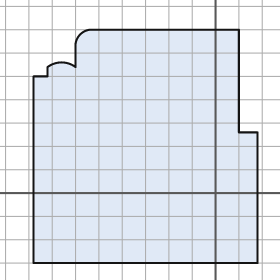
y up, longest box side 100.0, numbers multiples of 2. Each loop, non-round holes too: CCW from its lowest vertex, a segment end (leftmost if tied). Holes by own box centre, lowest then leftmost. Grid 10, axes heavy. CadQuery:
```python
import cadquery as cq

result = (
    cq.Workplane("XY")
    .moveTo(-78.0, -30.0)
    .lineTo(18.0, -30.0)
    .lineTo(18.0, 26.0)
    .lineTo(10.0, 26.0)
    .lineTo(10.0, 70.0)
    .lineTo(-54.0, 70.0)
    .threePointArc((-58.0, 68.0), (-60.0, 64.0))
    .lineTo(-60.0, 54.0)
    .threePointArc((-66.0, 56.0), (-72.0, 54.0))
    .lineTo(-72.0, 50.0)
    .lineTo(-78.0, 50.0)
    .close()
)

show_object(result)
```